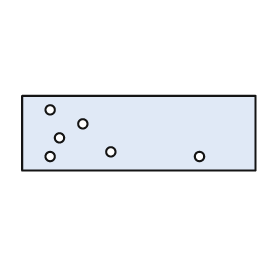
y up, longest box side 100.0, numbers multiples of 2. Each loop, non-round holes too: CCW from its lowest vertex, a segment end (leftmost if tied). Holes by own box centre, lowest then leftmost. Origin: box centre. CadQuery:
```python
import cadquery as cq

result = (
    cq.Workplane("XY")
    .moveTo(-50.0, -16.0)
    .lineTo(50.0, -16.0)
    .lineTo(50.0, 16.0)
    .lineTo(-50.0, 16.0)
    .close()
    .moveTo(-38.0, -10.0)
    .circle(2.0)
    .moveTo(26.0, -10.0)
    .circle(2.0)
    .moveTo(-12.0, -8.0)
    .circle(2.0)
    .moveTo(-34.0, -2.0)
    .circle(2.0)
    .moveTo(-24.0, 4.0)
    .circle(2.0)
    .moveTo(-38.0, 10.0)
    .circle(2.0)
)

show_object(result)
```